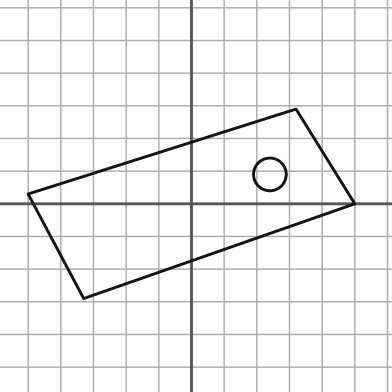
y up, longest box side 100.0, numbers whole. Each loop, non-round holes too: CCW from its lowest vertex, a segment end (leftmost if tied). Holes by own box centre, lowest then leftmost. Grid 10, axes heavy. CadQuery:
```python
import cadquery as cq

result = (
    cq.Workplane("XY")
    .moveTo(-33.0, -29.0)
    .lineTo(50.0, 0.0)
    .lineTo(32.0, 29.0)
    .lineTo(-50.0, 3.0)
    .close()
    .moveTo(24.0, 9.0)
    .circle(5.0)
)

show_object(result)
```